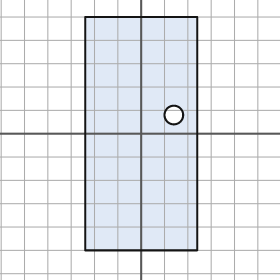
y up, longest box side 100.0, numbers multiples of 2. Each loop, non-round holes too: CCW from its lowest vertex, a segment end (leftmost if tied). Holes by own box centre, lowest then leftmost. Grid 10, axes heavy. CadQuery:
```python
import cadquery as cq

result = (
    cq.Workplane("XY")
    .moveTo(-24.0, -50.0)
    .lineTo(24.0, -50.0)
    .lineTo(24.0, 50.0)
    .lineTo(-24.0, 50.0)
    .close()
    .moveTo(14.0, 8.0)
    .circle(4.0)
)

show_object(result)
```